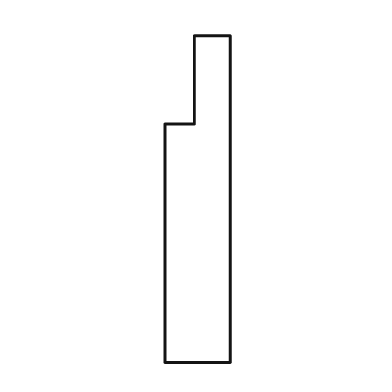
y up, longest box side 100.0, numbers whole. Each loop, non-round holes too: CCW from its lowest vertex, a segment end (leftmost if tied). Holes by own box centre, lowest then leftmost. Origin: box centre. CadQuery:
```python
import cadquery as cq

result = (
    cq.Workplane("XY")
    .moveTo(-10.0, -50.0)
    .lineTo(10.0, -50.0)
    .lineTo(10.0, 50.0)
    .lineTo(-1.0, 50.0)
    .lineTo(-1.0, 23.0)
    .lineTo(-10.0, 23.0)
    .close()
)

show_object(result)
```